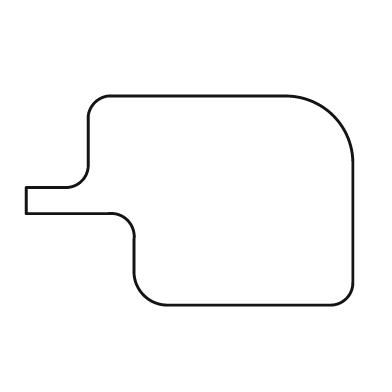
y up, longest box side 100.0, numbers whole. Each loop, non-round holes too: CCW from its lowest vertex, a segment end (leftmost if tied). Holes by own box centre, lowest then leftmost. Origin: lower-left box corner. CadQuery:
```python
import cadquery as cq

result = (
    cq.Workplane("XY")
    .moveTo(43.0, 0.0)
    .lineTo(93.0, 0.0)
    .threePointArc((98.0, 2.0), (100.0, 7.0))
    .lineTo(100.0, 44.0)
    .threePointArc((94.0, 58.0), (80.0, 64.0))
    .lineTo(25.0, 64.0)
    .threePointArc((21.0, 62.0), (19.0, 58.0))
    .lineTo(19.0, 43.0)
    .threePointArc((17.0, 38.0), (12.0, 36.0))
    .lineTo(0.0, 36.0)
    .lineTo(0.0, 28.0)
    .lineTo(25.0, 28.0)
    .threePointArc((31.0, 26.0), (33.0, 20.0))
    .lineTo(33.0, 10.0)
    .threePointArc((36.0, 3.0), (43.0, 0.0))
    .close()
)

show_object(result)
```